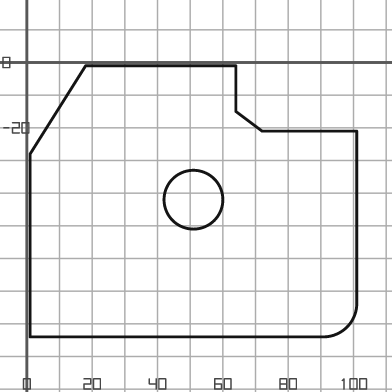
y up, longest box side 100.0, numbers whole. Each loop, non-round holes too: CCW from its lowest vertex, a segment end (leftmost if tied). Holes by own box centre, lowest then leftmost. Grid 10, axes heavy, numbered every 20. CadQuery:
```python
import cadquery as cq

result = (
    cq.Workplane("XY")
    .moveTo(1.0, -84.0)
    .lineTo(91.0, -84.0)
    .threePointArc((98.0, -81.0), (101.0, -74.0))
    .lineTo(101.0, -21.0)
    .lineTo(72.0, -21.0)
    .lineTo(64.0, -15.0)
    .lineTo(64.0, -1.0)
    .lineTo(18.0, -1.0)
    .lineTo(1.0, -28.0)
    .close()
    .moveTo(51.0, -42.0)
    .circle(9.0)
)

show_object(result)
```